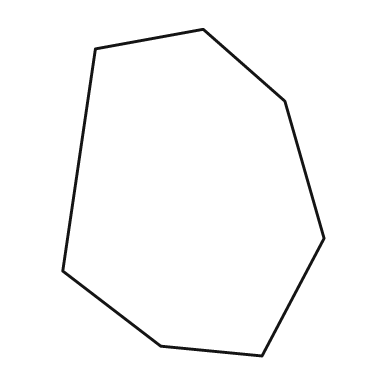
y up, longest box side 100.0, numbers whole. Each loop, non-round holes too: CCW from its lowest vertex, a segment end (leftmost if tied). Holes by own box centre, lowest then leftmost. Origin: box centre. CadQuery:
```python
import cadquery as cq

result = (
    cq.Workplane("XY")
    .moveTo(21.0, -50.0)
    .lineTo(40.0, -14.0)
    .lineTo(28.0, 28.0)
    .lineTo(3.0, 50.0)
    .lineTo(-30.0, 44.0)
    .lineTo(-40.0, -24.0)
    .lineTo(-10.0, -47.0)
    .close()
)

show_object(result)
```